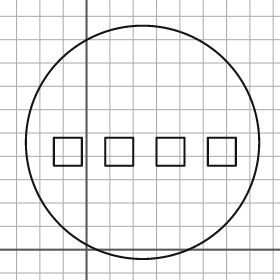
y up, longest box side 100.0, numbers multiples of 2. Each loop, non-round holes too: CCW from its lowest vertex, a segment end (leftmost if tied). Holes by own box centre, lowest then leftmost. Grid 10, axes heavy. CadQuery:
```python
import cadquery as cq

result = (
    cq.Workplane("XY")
    .moveTo(24.0, 46.0)
    .circle(50.0)
    .moveTo(-14.0, 36.0)
    .lineTo(-2.0, 36.0)
    .lineTo(-2.0, 48.0)
    .lineTo(-14.0, 48.0)
    .close()
    .moveTo(8.0, 36.0)
    .lineTo(20.0, 36.0)
    .lineTo(20.0, 48.0)
    .lineTo(8.0, 48.0)
    .close()
    .moveTo(30.0, 36.0)
    .lineTo(42.0, 36.0)
    .lineTo(42.0, 48.0)
    .lineTo(30.0, 48.0)
    .close()
    .moveTo(52.0, 36.0)
    .lineTo(64.0, 36.0)
    .lineTo(64.0, 48.0)
    .lineTo(52.0, 48.0)
    .close()
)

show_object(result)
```